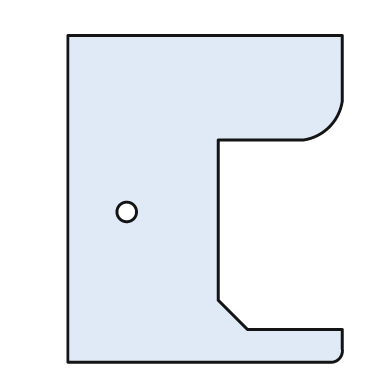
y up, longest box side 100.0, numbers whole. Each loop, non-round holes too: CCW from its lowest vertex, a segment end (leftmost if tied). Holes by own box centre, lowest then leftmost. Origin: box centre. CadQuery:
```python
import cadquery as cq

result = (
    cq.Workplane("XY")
    .moveTo(-42.0, -50.0)
    .lineTo(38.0, -50.0)
    .threePointArc((41.0, -49.0), (42.0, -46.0))
    .lineTo(42.0, -40.0)
    .lineTo(13.0, -40.0)
    .lineTo(4.0, -31.0)
    .lineTo(4.0, 18.0)
    .lineTo(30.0, 18.0)
    .threePointArc((38.0, 22.0), (42.0, 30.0))
    .lineTo(42.0, 50.0)
    .lineTo(-42.0, 50.0)
    .close()
    .moveTo(-24.0, -4.0)
    .circle(3.0)
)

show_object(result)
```